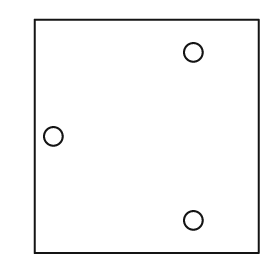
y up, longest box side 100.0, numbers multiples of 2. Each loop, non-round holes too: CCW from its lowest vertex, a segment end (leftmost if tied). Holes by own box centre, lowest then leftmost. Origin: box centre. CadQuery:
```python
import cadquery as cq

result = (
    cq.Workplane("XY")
    .moveTo(-48.0, -50.0)
    .lineTo(48.0, -50.0)
    .lineTo(48.0, 50.0)
    .lineTo(-48.0, 50.0)
    .close()
    .moveTo(20.0, -36.0)
    .circle(4.0)
    .moveTo(-40.0, 0.0)
    .circle(4.0)
    .moveTo(20.0, 36.0)
    .circle(4.0)
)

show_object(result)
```